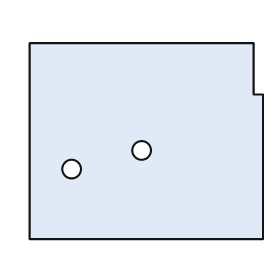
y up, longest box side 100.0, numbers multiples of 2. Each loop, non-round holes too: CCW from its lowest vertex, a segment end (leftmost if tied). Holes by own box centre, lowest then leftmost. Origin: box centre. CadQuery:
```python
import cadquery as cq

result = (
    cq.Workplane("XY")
    .moveTo(-50.0, -42.0)
    .lineTo(50.0, -42.0)
    .lineTo(50.0, 20.0)
    .lineTo(46.0, 20.0)
    .lineTo(46.0, 42.0)
    .lineTo(-50.0, 42.0)
    .close()
    .moveTo(-32.0, -12.0)
    .circle(4.0)
    .moveTo(-2.0, -4.0)
    .circle(4.0)
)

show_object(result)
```